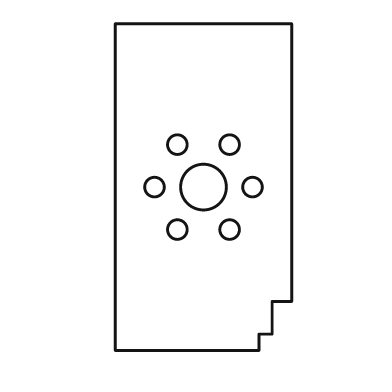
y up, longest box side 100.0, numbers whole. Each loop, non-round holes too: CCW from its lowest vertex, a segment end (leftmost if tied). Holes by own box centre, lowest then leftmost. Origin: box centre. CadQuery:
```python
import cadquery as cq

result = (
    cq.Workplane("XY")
    .moveTo(-27.0, -50.0)
    .lineTo(17.0, -50.0)
    .lineTo(17.0, -45.0)
    .lineTo(21.0, -45.0)
    .lineTo(21.0, -35.0)
    .lineTo(27.0, -35.0)
    .lineTo(27.0, 50.0)
    .lineTo(-27.0, 50.0)
    .close()
    .moveTo(-8.0, -13.0)
    .circle(3.0)
    .moveTo(8.0, -13.0)
    .circle(3.0)
    .moveTo(-15.0, 0.0)
    .circle(3.0)
    .moveTo(0.0, 0.0)
    .circle(7.0)
    .moveTo(15.0, 0.0)
    .circle(3.0)
    .moveTo(-8.0, 13.0)
    .circle(3.0)
    .moveTo(8.0, 13.0)
    .circle(3.0)
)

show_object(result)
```